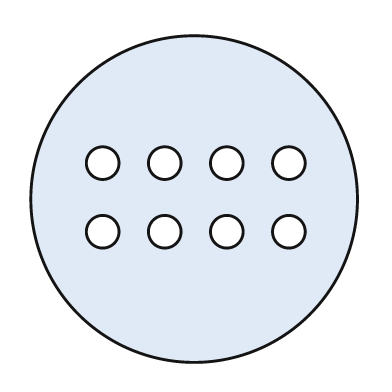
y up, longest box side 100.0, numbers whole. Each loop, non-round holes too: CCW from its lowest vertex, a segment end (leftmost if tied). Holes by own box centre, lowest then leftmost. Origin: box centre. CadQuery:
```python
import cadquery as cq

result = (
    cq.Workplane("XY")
    .moveTo(0.0, 0.0)
    .circle(50.0)
    .moveTo(-28.0, -10.0)
    .circle(5.0)
    .moveTo(-9.0, -10.0)
    .circle(5.0)
    .moveTo(10.0, -10.0)
    .circle(5.0)
    .moveTo(29.0, -10.0)
    .circle(5.0)
    .moveTo(-28.0, 11.0)
    .circle(5.0)
    .moveTo(-9.0, 11.0)
    .circle(5.0)
    .moveTo(10.0, 11.0)
    .circle(5.0)
    .moveTo(29.0, 11.0)
    .circle(5.0)
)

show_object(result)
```